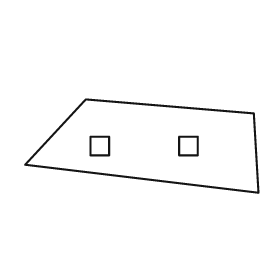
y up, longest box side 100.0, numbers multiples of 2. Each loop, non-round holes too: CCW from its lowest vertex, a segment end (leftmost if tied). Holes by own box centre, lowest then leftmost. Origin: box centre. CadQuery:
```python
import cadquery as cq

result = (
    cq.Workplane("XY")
    .moveTo(50.0, -20.0)
    .lineTo(48.0, 14.0)
    .lineTo(-24.0, 20.0)
    .lineTo(-50.0, -8.0)
    .close()
    .moveTo(-22.0, -4.0)
    .lineTo(-14.0, -4.0)
    .lineTo(-14.0, 4.0)
    .lineTo(-22.0, 4.0)
    .close()
    .moveTo(16.0, -4.0)
    .lineTo(24.0, -4.0)
    .lineTo(24.0, 4.0)
    .lineTo(16.0, 4.0)
    .close()
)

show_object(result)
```